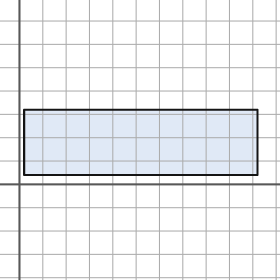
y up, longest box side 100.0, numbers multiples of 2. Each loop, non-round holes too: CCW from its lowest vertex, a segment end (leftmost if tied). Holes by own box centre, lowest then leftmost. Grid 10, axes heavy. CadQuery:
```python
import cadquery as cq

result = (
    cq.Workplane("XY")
    .moveTo(2.0, 4.0)
    .lineTo(102.0, 4.0)
    .lineTo(102.0, 32.0)
    .lineTo(2.0, 32.0)
    .close()
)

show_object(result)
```